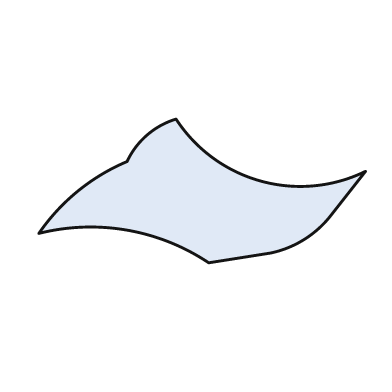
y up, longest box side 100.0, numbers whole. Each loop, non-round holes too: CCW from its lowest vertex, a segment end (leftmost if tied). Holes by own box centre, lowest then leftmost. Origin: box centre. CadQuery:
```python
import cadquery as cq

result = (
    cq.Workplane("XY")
    .moveTo(2.0, -22.0)
    .lineTo(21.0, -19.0)
    .threePointArc((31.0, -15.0), (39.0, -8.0))
    .lineTo(50.0, 6.0)
    .threePointArc((18.0, 3.0), (-8.0, 22.0))
    .threePointArc((-17.0, 17.0), (-23.0, 9.0))
    .threePointArc((-38.0, 0.0), (-50.0, -13.0))
    .threePointArc((-23.0, -12.0), (2.0, -22.0))
    .close()
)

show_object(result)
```